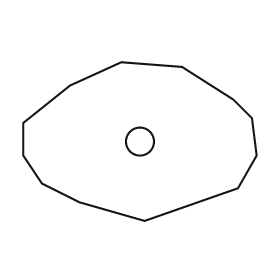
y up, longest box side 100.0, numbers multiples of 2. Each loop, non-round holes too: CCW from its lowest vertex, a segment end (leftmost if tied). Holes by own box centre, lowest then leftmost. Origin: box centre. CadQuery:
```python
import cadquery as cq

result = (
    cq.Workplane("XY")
    .moveTo(2.0, -34.0)
    .lineTo(42.0, -20.0)
    .lineTo(50.0, -6.0)
    .lineTo(48.0, 10.0)
    .lineTo(40.0, 18.0)
    .lineTo(18.0, 32.0)
    .lineTo(-8.0, 34.0)
    .lineTo(-30.0, 24.0)
    .lineTo(-50.0, 8.0)
    .lineTo(-50.0, -6.0)
    .lineTo(-42.0, -18.0)
    .lineTo(-26.0, -26.0)
    .close()
    .moveTo(0.0, 0.0)
    .circle(6.0)
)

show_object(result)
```